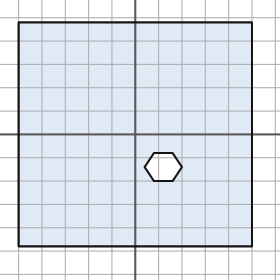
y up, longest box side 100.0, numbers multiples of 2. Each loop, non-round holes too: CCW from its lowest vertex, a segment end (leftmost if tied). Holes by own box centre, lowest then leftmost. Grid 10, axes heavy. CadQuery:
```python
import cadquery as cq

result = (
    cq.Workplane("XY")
    .moveTo(-50.0, -48.0)
    .lineTo(50.0, -48.0)
    .lineTo(50.0, 48.0)
    .lineTo(-50.0, 48.0)
    .close()
    .moveTo(8.0, -20.0)
    .lineTo(16.0, -20.0)
    .lineTo(20.0, -14.0)
    .lineTo(16.0, -8.0)
    .lineTo(8.0, -8.0)
    .lineTo(4.0, -14.0)
    .close()
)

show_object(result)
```